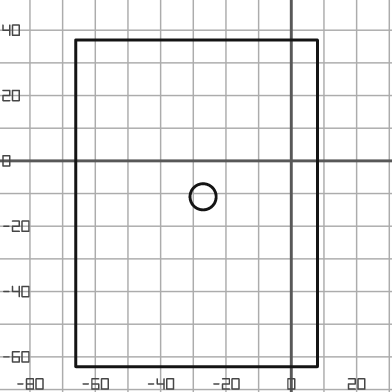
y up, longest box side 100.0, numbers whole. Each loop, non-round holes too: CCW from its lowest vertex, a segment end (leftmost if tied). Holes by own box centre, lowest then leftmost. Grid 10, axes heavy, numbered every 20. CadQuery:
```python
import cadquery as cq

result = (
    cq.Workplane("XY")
    .moveTo(-66.0, -63.0)
    .lineTo(8.0, -63.0)
    .lineTo(8.0, 37.0)
    .lineTo(-66.0, 37.0)
    .close()
    .moveTo(-27.0, -11.0)
    .circle(4.0)
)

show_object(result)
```